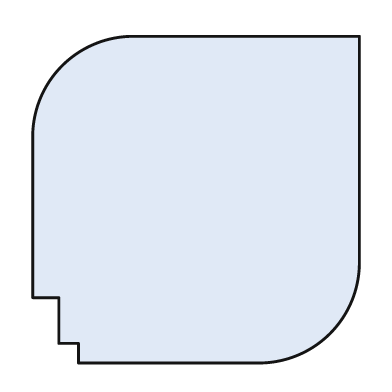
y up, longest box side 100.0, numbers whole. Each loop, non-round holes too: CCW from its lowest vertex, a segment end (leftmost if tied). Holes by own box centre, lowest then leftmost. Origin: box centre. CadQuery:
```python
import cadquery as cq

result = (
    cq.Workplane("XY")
    .moveTo(-36.0, -50.0)
    .lineTo(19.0, -50.0)
    .threePointArc((41.0, -41.0), (50.0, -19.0))
    .lineTo(50.0, 50.0)
    .lineTo(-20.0, 50.0)
    .threePointArc((-41.0, 41.0), (-50.0, 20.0))
    .lineTo(-50.0, -30.0)
    .lineTo(-42.0, -30.0)
    .lineTo(-42.0, -44.0)
    .lineTo(-36.0, -44.0)
    .close()
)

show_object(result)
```